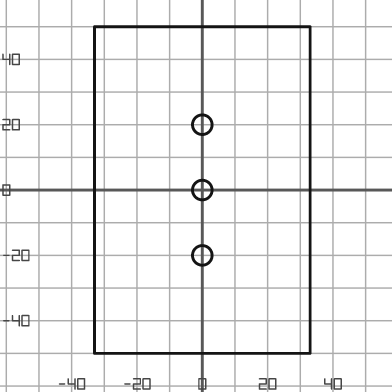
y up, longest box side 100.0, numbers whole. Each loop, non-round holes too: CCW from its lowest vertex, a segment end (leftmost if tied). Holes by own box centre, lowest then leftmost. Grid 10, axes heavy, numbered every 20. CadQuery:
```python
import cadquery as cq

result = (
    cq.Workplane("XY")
    .moveTo(-33.0, -50.0)
    .lineTo(33.0, -50.0)
    .lineTo(33.0, 50.0)
    .lineTo(-33.0, 50.0)
    .close()
    .moveTo(0.0, -20.0)
    .circle(3.0)
    .moveTo(0.0, 0.0)
    .circle(3.0)
    .moveTo(0.0, 20.0)
    .circle(3.0)
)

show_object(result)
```